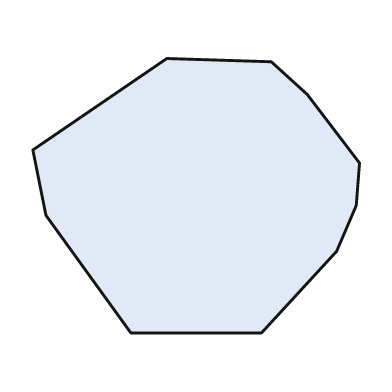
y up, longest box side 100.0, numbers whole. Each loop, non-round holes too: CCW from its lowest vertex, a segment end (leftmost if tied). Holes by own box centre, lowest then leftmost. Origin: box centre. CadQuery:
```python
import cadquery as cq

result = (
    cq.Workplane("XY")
    .moveTo(-20.0, -42.0)
    .lineTo(20.0, -42.0)
    .lineTo(43.0, -17.0)
    .lineTo(49.0, -3.0)
    .lineTo(50.0, 10.0)
    .lineTo(34.0, 31.0)
    .lineTo(23.0, 41.0)
    .lineTo(-9.0, 42.0)
    .lineTo(-50.0, 14.0)
    .lineTo(-46.0, -6.0)
    .close()
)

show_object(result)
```